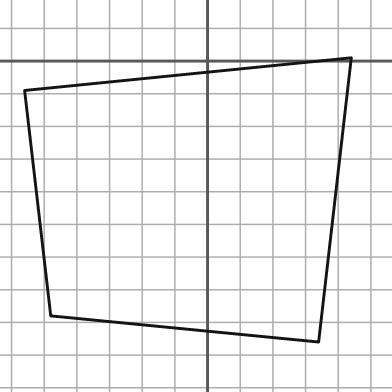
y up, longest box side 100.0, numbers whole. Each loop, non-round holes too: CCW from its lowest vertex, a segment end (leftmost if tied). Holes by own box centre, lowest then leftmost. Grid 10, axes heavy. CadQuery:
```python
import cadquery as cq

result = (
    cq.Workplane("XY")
    .moveTo(34.0, -86.0)
    .lineTo(44.0, 1.0)
    .lineTo(-56.0, -9.0)
    .lineTo(-48.0, -78.0)
    .close()
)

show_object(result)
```